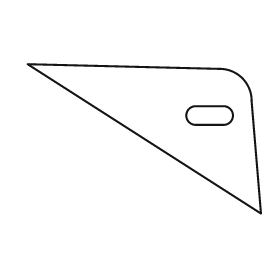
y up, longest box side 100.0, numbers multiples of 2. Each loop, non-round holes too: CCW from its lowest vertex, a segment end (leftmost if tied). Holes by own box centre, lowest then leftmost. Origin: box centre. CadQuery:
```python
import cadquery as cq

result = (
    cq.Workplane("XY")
    .moveTo(50.0, -32.0)
    .lineTo(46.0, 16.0)
    .threePointArc((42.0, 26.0), (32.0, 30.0))
    .lineTo(-50.0, 32.0)
    .close()
    .moveTo(22.0, 6.0)
    .lineTo(34.0, 6.0)
    .threePointArc((38.0, 10.0), (34.0, 14.0))
    .lineTo(22.0, 14.0)
    .threePointArc((18.0, 10.0), (22.0, 6.0))
    .close()
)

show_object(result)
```